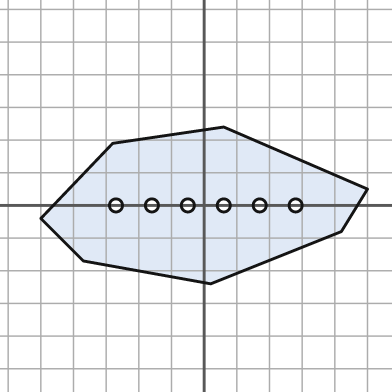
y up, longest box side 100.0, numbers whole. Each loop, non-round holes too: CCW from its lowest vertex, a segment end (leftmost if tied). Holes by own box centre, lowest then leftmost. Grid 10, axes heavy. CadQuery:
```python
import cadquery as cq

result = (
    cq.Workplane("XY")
    .moveTo(2.0, -24.0)
    .lineTo(42.0, -8.0)
    .lineTo(50.0, 5.0)
    .lineTo(6.0, 24.0)
    .lineTo(-28.0, 19.0)
    .lineTo(-50.0, -4.0)
    .lineTo(-37.0, -17.0)
    .close()
    .moveTo(-27.0, 0.0)
    .circle(2.0)
    .moveTo(-16.0, 0.0)
    .circle(2.0)
    .moveTo(-5.0, 0.0)
    .circle(2.0)
    .moveTo(6.0, 0.0)
    .circle(2.0)
    .moveTo(17.0, 0.0)
    .circle(2.0)
    .moveTo(28.0, 0.0)
    .circle(2.0)
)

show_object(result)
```